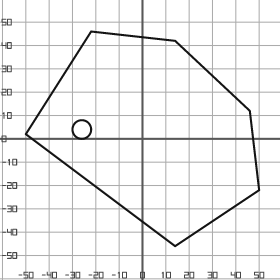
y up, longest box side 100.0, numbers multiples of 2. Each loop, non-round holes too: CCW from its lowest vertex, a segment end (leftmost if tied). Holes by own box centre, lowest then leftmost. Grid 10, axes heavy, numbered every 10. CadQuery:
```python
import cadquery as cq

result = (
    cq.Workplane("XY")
    .moveTo(14.0, -46.0)
    .lineTo(50.0, -22.0)
    .lineTo(46.0, 12.0)
    .lineTo(14.0, 42.0)
    .lineTo(-22.0, 46.0)
    .lineTo(-50.0, 2.0)
    .close()
    .moveTo(-26.0, 4.0)
    .circle(4.0)
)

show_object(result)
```